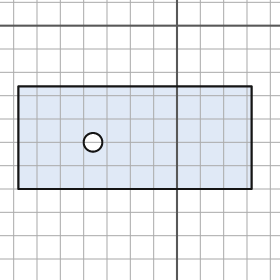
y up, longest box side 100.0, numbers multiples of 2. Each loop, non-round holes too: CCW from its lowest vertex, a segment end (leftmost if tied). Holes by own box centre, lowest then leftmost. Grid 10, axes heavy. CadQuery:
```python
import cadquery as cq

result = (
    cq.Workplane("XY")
    .moveTo(-68.0, -70.0)
    .lineTo(32.0, -70.0)
    .lineTo(32.0, -26.0)
    .lineTo(-68.0, -26.0)
    .close()
    .moveTo(-36.0, -50.0)
    .circle(4.0)
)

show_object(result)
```